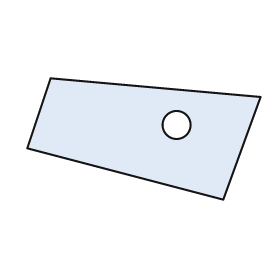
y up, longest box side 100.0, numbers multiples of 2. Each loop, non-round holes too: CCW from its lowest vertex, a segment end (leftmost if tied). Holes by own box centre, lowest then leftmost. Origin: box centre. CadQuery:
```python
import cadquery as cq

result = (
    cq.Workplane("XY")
    .moveTo(34.0, -26.0)
    .lineTo(50.0, 18.0)
    .lineTo(-40.0, 26.0)
    .lineTo(-50.0, -4.0)
    .close()
    .moveTo(14.0, 6.0)
    .circle(6.0)
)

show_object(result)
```